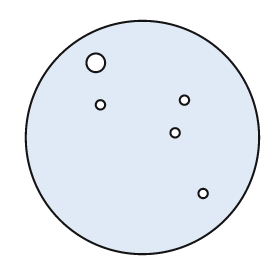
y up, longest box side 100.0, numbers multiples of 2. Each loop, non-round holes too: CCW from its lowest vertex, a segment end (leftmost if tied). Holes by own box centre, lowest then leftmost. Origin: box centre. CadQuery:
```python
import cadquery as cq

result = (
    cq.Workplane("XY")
    .moveTo(0.0, 0.0)
    .circle(50.0)
    .moveTo(26.0, -24.0)
    .circle(2.0)
    .moveTo(14.0, 2.0)
    .circle(2.0)
    .moveTo(-18.0, 14.0)
    .circle(2.0)
    .moveTo(18.0, 16.0)
    .circle(2.0)
    .moveTo(-20.0, 32.0)
    .circle(4.0)
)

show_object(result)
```